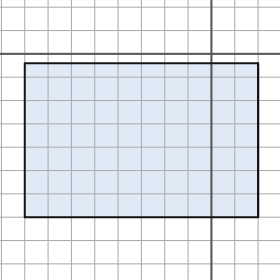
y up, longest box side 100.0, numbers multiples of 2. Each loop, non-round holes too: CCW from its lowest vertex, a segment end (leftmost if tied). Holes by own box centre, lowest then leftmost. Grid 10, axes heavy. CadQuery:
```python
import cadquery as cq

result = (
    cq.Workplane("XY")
    .moveTo(-80.0, -70.0)
    .lineTo(20.0, -70.0)
    .lineTo(20.0, -4.0)
    .lineTo(-80.0, -4.0)
    .close()
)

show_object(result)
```